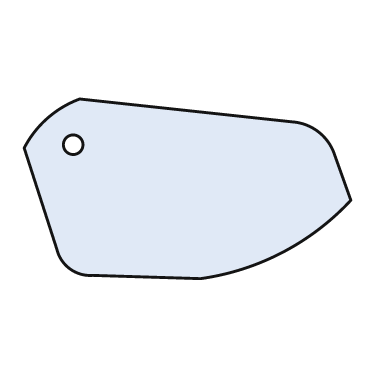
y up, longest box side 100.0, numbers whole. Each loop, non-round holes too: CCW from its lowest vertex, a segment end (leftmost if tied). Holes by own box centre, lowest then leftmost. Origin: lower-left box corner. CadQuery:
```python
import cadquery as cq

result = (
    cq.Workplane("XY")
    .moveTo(54.0, 0.0)
    .threePointArc((79.0, 8.0), (100.0, 24.0))
    .lineTo(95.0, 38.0)
    .threePointArc((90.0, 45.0), (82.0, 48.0))
    .lineTo(17.0, 55.0)
    .threePointArc((7.0, 49.0), (0.0, 40.0))
    .lineTo(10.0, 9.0)
    .threePointArc((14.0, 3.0), (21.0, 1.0))
    .close()
    .moveTo(15.0, 41.0)
    .circle(3.0)
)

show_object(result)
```